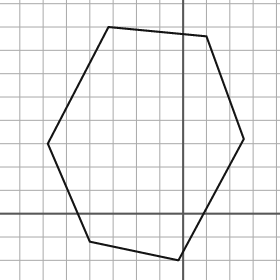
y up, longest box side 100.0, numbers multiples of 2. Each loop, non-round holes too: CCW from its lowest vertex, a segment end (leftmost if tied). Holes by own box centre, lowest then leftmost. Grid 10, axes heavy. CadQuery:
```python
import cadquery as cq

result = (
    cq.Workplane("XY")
    .moveTo(-2.0, -20.0)
    .lineTo(26.0, 32.0)
    .lineTo(10.0, 76.0)
    .lineTo(-32.0, 80.0)
    .lineTo(-58.0, 30.0)
    .lineTo(-40.0, -12.0)
    .close()
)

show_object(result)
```